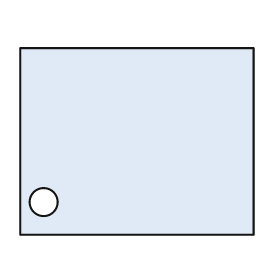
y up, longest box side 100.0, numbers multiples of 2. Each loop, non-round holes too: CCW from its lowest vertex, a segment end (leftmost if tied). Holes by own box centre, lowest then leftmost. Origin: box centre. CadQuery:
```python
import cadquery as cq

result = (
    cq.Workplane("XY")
    .moveTo(-50.0, -40.0)
    .lineTo(50.0, -40.0)
    .lineTo(50.0, 40.0)
    .lineTo(-50.0, 40.0)
    .close()
    .moveTo(-40.0, -26.0)
    .circle(6.0)
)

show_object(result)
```